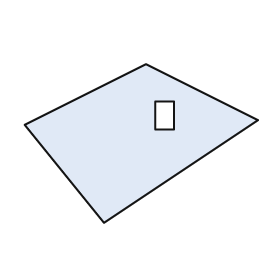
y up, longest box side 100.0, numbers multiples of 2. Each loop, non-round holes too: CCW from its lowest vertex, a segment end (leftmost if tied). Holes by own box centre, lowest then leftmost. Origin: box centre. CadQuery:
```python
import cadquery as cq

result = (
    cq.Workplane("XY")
    .moveTo(-16.0, -34.0)
    .lineTo(50.0, 10.0)
    .lineTo(2.0, 34.0)
    .lineTo(-50.0, 8.0)
    .close()
    .moveTo(6.0, 6.0)
    .lineTo(14.0, 6.0)
    .lineTo(14.0, 18.0)
    .lineTo(6.0, 18.0)
    .close()
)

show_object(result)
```